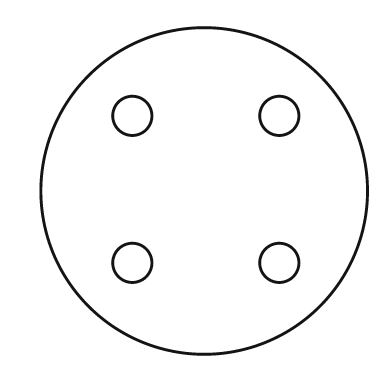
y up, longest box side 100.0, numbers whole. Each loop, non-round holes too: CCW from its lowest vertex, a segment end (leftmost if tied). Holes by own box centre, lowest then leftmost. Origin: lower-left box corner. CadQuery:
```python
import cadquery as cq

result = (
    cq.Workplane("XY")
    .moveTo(50.0, 50.0)
    .circle(50.0)
    .moveTo(28.0, 28.0)
    .circle(6.0)
    .moveTo(73.0, 28.0)
    .circle(6.0)
    .moveTo(28.0, 73.0)
    .circle(6.0)
    .moveTo(73.0, 73.0)
    .circle(6.0)
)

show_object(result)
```